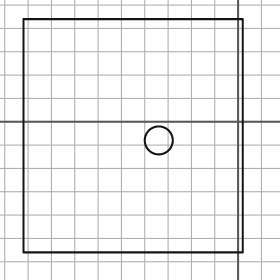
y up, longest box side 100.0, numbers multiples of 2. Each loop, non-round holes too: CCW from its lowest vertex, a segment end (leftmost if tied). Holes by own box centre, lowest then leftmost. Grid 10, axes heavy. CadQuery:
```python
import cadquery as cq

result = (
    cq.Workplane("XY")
    .moveTo(-92.0, -56.0)
    .lineTo(2.0, -56.0)
    .lineTo(2.0, 44.0)
    .lineTo(-92.0, 44.0)
    .close()
    .moveTo(-34.0, -8.0)
    .circle(6.0)
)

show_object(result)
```